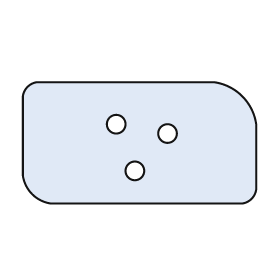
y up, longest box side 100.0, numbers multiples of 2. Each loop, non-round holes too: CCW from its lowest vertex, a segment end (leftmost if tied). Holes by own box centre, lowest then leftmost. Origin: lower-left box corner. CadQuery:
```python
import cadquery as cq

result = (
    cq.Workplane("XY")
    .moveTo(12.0, 0.0)
    .lineTo(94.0, 0.0)
    .threePointArc((98.0, 2.0), (100.0, 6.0))
    .lineTo(100.0, 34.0)
    .threePointArc((94.0, 46.0), (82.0, 52.0))
    .lineTo(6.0, 52.0)
    .threePointArc((2.0, 50.0), (0.0, 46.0))
    .lineTo(0.0, 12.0)
    .threePointArc((4.0, 4.0), (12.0, 0.0))
    .close()
    .moveTo(48.0, 14.0)
    .circle(4.0)
    .moveTo(62.0, 30.0)
    .circle(4.0)
    .moveTo(40.0, 34.0)
    .circle(4.0)
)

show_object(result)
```